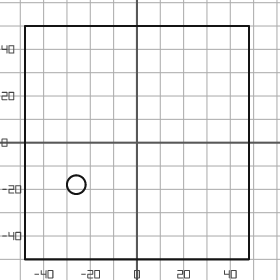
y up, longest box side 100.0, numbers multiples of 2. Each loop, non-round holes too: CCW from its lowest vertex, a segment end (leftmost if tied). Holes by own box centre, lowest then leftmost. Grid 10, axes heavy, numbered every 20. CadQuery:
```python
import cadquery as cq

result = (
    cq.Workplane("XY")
    .moveTo(-48.0, -50.0)
    .lineTo(48.0, -50.0)
    .lineTo(48.0, 50.0)
    .lineTo(-48.0, 50.0)
    .close()
    .moveTo(-26.0, -18.0)
    .circle(4.0)
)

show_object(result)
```